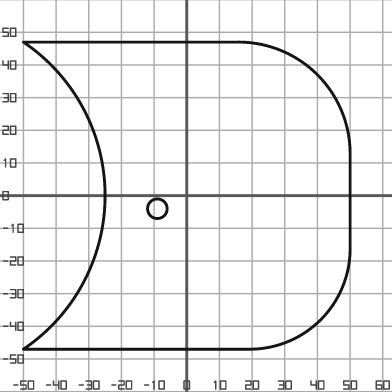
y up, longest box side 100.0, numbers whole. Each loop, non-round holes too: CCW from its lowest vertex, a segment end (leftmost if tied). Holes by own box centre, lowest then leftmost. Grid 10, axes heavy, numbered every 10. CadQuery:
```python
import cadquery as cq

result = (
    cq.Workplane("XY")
    .moveTo(-50.0, -47.0)
    .lineTo(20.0, -47.0)
    .threePointArc((41.0, -38.0), (50.0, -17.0))
    .lineTo(50.0, 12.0)
    .threePointArc((40.0, 37.0), (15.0, 47.0))
    .lineTo(-50.0, 47.0)
    .threePointArc((-25.0, 0.0), (-50.0, -47.0))
    .close()
    .moveTo(-9.0, -4.0)
    .circle(3.0)
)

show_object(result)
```